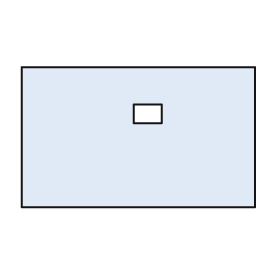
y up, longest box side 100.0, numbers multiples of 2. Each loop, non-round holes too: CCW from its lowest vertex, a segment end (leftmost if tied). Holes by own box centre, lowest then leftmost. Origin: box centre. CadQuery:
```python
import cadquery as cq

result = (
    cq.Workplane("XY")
    .moveTo(-50.0, -30.0)
    .lineTo(50.0, -30.0)
    .lineTo(50.0, 30.0)
    .lineTo(-50.0, 30.0)
    .close()
    .moveTo(-2.0, 6.0)
    .lineTo(10.0, 6.0)
    .lineTo(10.0, 14.0)
    .lineTo(-2.0, 14.0)
    .close()
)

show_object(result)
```